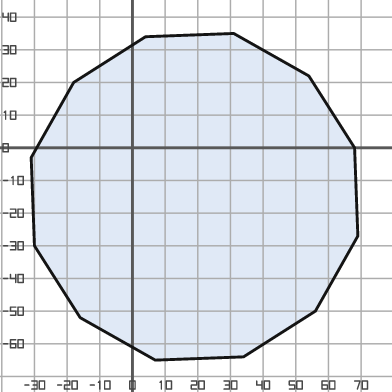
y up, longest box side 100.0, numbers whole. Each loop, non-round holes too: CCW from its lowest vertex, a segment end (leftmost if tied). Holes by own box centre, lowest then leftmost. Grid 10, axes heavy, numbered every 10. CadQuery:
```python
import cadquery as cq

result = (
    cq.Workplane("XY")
    .moveTo(7.0, -65.0)
    .lineTo(34.0, -64.0)
    .lineTo(56.0, -50.0)
    .lineTo(69.0, -27.0)
    .lineTo(68.0, 0.0)
    .lineTo(54.0, 22.0)
    .lineTo(31.0, 35.0)
    .lineTo(4.0, 34.0)
    .lineTo(-18.0, 20.0)
    .lineTo(-31.0, -3.0)
    .lineTo(-30.0, -30.0)
    .lineTo(-16.0, -52.0)
    .close()
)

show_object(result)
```